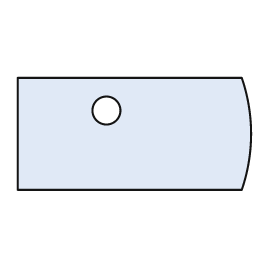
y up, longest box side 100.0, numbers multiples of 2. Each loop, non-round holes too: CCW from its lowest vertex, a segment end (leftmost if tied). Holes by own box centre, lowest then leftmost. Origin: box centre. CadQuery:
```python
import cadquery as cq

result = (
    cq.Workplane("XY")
    .moveTo(-50.0, -24.0)
    .lineTo(46.0, -24.0)
    .threePointArc((50.0, 0.0), (46.0, 24.0))
    .lineTo(-50.0, 24.0)
    .close()
    .moveTo(-12.0, 10.0)
    .circle(6.0)
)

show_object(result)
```